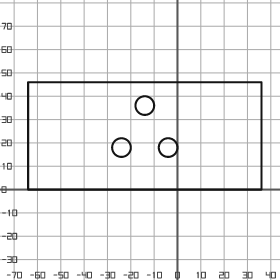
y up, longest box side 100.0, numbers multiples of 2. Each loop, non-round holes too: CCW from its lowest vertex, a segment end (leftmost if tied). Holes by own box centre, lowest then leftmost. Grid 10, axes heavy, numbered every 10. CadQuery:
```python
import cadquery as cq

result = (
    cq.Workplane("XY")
    .moveTo(-64.0, 0.0)
    .lineTo(36.0, 0.0)
    .lineTo(36.0, 46.0)
    .lineTo(-64.0, 46.0)
    .close()
    .moveTo(-24.0, 18.0)
    .circle(4.0)
    .moveTo(-4.0, 18.0)
    .circle(4.0)
    .moveTo(-14.0, 36.0)
    .circle(4.0)
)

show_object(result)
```